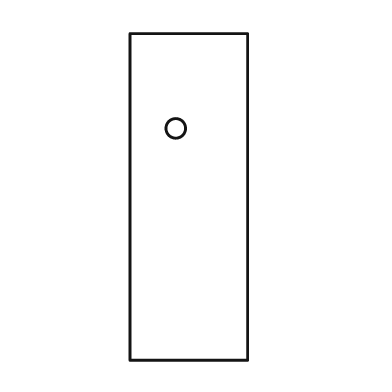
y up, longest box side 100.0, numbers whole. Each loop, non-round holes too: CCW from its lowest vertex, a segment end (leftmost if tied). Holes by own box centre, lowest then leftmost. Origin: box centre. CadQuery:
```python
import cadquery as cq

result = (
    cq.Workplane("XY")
    .moveTo(-18.0, -50.0)
    .lineTo(18.0, -50.0)
    .lineTo(18.0, 50.0)
    .lineTo(-18.0, 50.0)
    .close()
    .moveTo(-4.0, 21.0)
    .circle(3.0)
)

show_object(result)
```